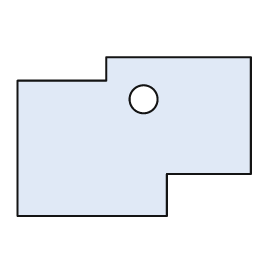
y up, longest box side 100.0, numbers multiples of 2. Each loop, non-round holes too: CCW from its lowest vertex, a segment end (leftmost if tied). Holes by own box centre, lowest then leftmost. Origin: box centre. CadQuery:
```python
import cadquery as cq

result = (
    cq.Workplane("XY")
    .moveTo(-50.0, -34.0)
    .lineTo(14.0, -34.0)
    .lineTo(14.0, -16.0)
    .lineTo(50.0, -16.0)
    .lineTo(50.0, 34.0)
    .lineTo(-12.0, 34.0)
    .lineTo(-12.0, 24.0)
    .lineTo(-50.0, 24.0)
    .close()
    .moveTo(4.0, 16.0)
    .circle(6.0)
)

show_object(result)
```